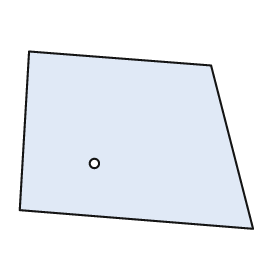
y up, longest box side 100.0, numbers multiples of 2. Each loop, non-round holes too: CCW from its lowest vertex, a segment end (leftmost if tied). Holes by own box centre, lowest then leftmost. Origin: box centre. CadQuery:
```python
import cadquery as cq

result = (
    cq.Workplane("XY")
    .moveTo(50.0, -38.0)
    .lineTo(32.0, 32.0)
    .lineTo(-46.0, 38.0)
    .lineTo(-50.0, -30.0)
    .close()
    .moveTo(-18.0, -10.0)
    .circle(2.0)
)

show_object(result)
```